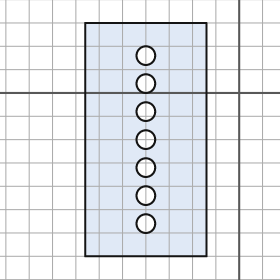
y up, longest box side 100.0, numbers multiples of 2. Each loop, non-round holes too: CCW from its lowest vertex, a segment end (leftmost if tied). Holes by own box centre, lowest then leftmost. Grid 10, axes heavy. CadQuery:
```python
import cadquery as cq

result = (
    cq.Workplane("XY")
    .moveTo(-66.0, -70.0)
    .lineTo(-14.0, -70.0)
    .lineTo(-14.0, 30.0)
    .lineTo(-66.0, 30.0)
    .close()
    .moveTo(-40.0, -56.0)
    .circle(4.0)
    .moveTo(-40.0, -44.0)
    .circle(4.0)
    .moveTo(-40.0, -32.0)
    .circle(4.0)
    .moveTo(-40.0, -20.0)
    .circle(4.0)
    .moveTo(-40.0, -8.0)
    .circle(4.0)
    .moveTo(-40.0, 4.0)
    .circle(4.0)
    .moveTo(-40.0, 16.0)
    .circle(4.0)
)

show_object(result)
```